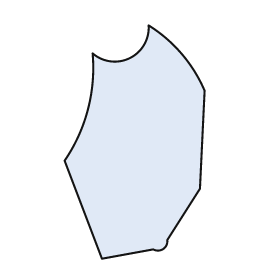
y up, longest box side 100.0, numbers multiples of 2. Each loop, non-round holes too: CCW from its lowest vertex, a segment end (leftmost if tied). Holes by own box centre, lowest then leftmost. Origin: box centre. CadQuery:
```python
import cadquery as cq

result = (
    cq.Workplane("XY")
    .moveTo(-14.0, -50.0)
    .lineTo(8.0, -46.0)
    .threePointArc((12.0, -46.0), (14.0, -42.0))
    .lineTo(28.0, -20.0)
    .lineTo(30.0, 22.0)
    .threePointArc((20.0, 38.0), (6.0, 50.0))
    .threePointArc((-2.0, 36.0), (-18.0, 38.0))
    .threePointArc((-20.0, 14.0), (-30.0, -8.0))
    .close()
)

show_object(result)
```